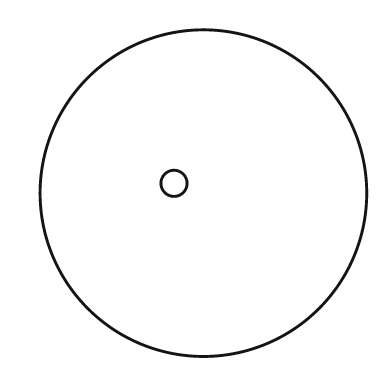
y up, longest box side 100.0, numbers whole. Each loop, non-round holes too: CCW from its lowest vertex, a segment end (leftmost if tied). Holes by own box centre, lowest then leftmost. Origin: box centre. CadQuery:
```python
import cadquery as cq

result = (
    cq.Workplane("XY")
    .moveTo(0.0, 0.0)
    .circle(50.0)
    .moveTo(-9.0, 3.0)
    .circle(4.0)
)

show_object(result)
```